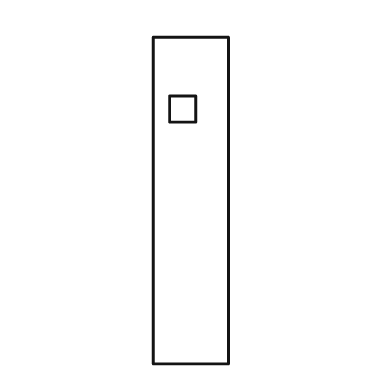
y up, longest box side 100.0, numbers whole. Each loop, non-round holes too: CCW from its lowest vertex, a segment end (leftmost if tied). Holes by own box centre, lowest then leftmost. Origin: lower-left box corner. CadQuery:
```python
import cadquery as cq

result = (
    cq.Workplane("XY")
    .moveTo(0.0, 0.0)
    .lineTo(23.0, 0.0)
    .lineTo(23.0, 100.0)
    .lineTo(0.0, 100.0)
    .close()
    .moveTo(5.0, 74.0)
    .lineTo(13.0, 74.0)
    .lineTo(13.0, 82.0)
    .lineTo(5.0, 82.0)
    .close()
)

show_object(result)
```